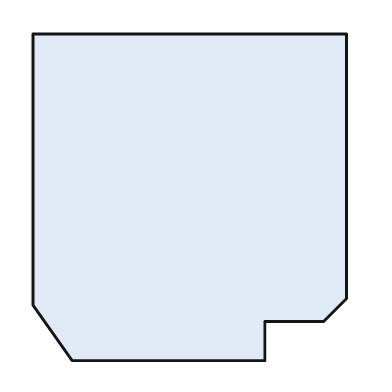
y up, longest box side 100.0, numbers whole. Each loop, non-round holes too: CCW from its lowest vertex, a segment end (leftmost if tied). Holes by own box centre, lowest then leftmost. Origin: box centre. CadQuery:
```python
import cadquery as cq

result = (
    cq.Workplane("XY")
    .moveTo(-36.0, -50.0)
    .lineTo(23.0, -50.0)
    .lineTo(23.0, -38.0)
    .lineTo(41.0, -38.0)
    .lineTo(48.0, -31.0)
    .lineTo(48.0, 50.0)
    .lineTo(-48.0, 50.0)
    .lineTo(-48.0, -33.0)
    .close()
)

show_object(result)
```